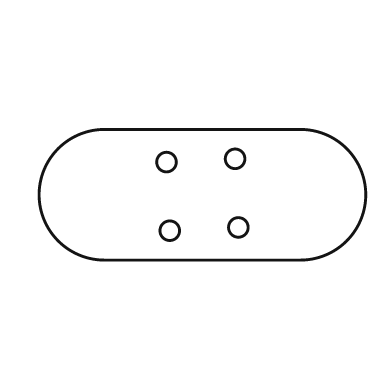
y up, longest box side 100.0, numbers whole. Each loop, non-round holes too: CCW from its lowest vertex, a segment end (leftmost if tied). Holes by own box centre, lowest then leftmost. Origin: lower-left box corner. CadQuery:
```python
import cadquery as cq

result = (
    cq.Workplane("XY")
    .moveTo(20.0, 0.0)
    .lineTo(80.0, 0.0)
    .threePointArc((100.0, 20.0), (80.0, 40.0))
    .lineTo(20.0, 40.0)
    .threePointArc((0.0, 20.0), (20.0, 0.0))
    .close()
    .moveTo(40.0, 9.0)
    .circle(3.0)
    .moveTo(61.0, 10.0)
    .circle(3.0)
    .moveTo(39.0, 30.0)
    .circle(3.0)
    .moveTo(60.0, 31.0)
    .circle(3.0)
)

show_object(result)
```